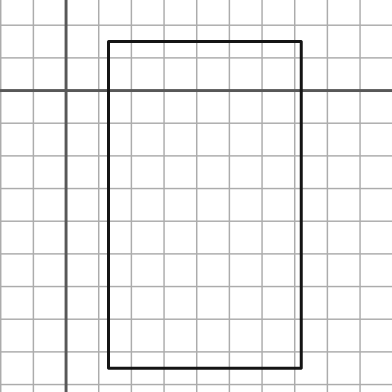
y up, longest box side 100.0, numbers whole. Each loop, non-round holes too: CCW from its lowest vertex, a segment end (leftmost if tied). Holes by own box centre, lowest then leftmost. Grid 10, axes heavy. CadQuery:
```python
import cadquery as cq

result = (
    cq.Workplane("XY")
    .moveTo(13.0, -85.0)
    .lineTo(72.0, -85.0)
    .lineTo(72.0, 15.0)
    .lineTo(13.0, 15.0)
    .close()
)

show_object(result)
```